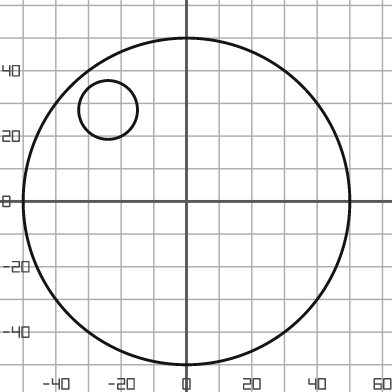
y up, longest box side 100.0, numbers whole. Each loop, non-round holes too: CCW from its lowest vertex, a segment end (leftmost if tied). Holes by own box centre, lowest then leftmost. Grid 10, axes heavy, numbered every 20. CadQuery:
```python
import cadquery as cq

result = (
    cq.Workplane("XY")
    .moveTo(0.0, 0.0)
    .circle(50.0)
    .moveTo(-24.0, 28.0)
    .circle(9.0)
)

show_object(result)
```